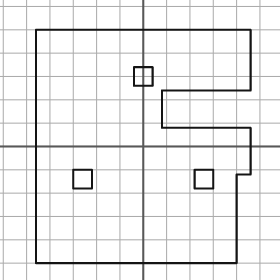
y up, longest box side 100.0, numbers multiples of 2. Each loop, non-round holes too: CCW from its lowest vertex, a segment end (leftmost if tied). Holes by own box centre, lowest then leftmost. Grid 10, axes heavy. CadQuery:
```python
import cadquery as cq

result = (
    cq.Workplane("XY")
    .moveTo(-46.0, -50.0)
    .lineTo(40.0, -50.0)
    .lineTo(40.0, -12.0)
    .lineTo(46.0, -12.0)
    .lineTo(46.0, 8.0)
    .lineTo(8.0, 8.0)
    .lineTo(8.0, 24.0)
    .lineTo(46.0, 24.0)
    .lineTo(46.0, 50.0)
    .lineTo(-46.0, 50.0)
    .close()
    .moveTo(-30.0, -18.0)
    .lineTo(-22.0, -18.0)
    .lineTo(-22.0, -10.0)
    .lineTo(-30.0, -10.0)
    .close()
    .moveTo(22.0, -18.0)
    .lineTo(30.0, -18.0)
    .lineTo(30.0, -10.0)
    .lineTo(22.0, -10.0)
    .close()
    .moveTo(-4.0, 26.0)
    .lineTo(4.0, 26.0)
    .lineTo(4.0, 34.0)
    .lineTo(-4.0, 34.0)
    .close()
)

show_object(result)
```